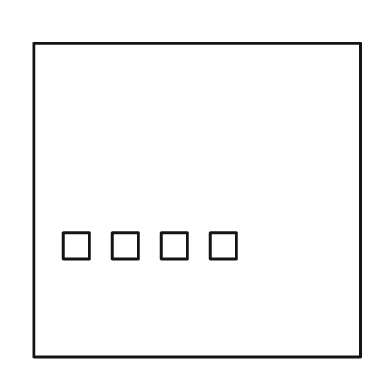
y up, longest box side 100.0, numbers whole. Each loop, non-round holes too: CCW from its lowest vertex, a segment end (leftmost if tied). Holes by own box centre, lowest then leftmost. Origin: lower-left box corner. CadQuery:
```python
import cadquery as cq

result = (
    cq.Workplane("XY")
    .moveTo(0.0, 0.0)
    .lineTo(100.0, 0.0)
    .lineTo(100.0, 96.0)
    .lineTo(0.0, 96.0)
    .close()
    .moveTo(9.0, 30.0)
    .lineTo(17.0, 30.0)
    .lineTo(17.0, 38.0)
    .lineTo(9.0, 38.0)
    .close()
    .moveTo(24.0, 30.0)
    .lineTo(32.0, 30.0)
    .lineTo(32.0, 38.0)
    .lineTo(24.0, 38.0)
    .close()
    .moveTo(39.0, 30.0)
    .lineTo(47.0, 30.0)
    .lineTo(47.0, 38.0)
    .lineTo(39.0, 38.0)
    .close()
    .moveTo(54.0, 30.0)
    .lineTo(62.0, 30.0)
    .lineTo(62.0, 38.0)
    .lineTo(54.0, 38.0)
    .close()
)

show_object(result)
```